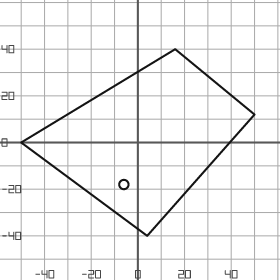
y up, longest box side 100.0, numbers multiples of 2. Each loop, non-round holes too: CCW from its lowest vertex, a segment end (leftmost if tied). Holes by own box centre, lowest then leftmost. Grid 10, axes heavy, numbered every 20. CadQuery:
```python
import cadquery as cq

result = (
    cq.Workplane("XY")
    .moveTo(4.0, -40.0)
    .lineTo(50.0, 12.0)
    .lineTo(16.0, 40.0)
    .lineTo(-50.0, 0.0)
    .close()
    .moveTo(-6.0, -18.0)
    .circle(2.0)
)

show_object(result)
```